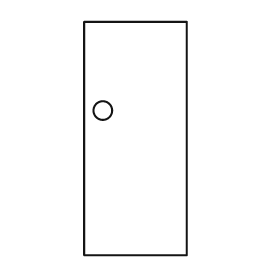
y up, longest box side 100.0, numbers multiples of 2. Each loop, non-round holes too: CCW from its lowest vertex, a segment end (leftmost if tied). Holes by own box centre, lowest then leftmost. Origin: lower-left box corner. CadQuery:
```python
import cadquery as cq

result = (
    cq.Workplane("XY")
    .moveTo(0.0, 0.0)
    .lineTo(44.0, 0.0)
    .lineTo(44.0, 100.0)
    .lineTo(0.0, 100.0)
    .close()
    .moveTo(8.0, 62.0)
    .circle(4.0)
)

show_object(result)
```